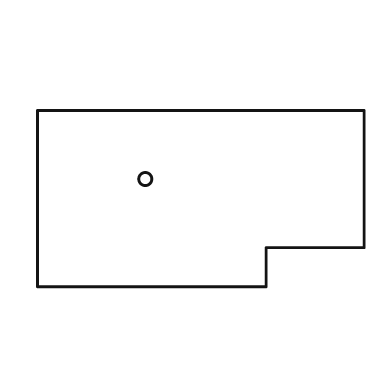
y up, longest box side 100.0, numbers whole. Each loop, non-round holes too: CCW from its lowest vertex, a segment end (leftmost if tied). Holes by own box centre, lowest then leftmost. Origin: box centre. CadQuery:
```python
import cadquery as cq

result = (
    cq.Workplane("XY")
    .moveTo(-50.0, -27.0)
    .lineTo(20.0, -27.0)
    .lineTo(20.0, -15.0)
    .lineTo(50.0, -15.0)
    .lineTo(50.0, 27.0)
    .lineTo(-50.0, 27.0)
    .close()
    .moveTo(-17.0, 6.0)
    .circle(2.0)
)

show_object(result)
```